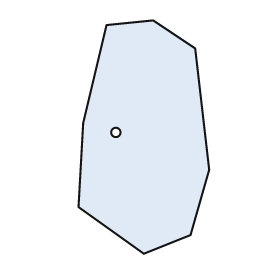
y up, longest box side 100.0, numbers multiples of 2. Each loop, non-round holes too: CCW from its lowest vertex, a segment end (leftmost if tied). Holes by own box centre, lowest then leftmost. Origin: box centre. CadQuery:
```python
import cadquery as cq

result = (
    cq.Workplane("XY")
    .moveTo(0.0, -50.0)
    .lineTo(20.0, -42.0)
    .lineTo(28.0, -14.0)
    .lineTo(22.0, 38.0)
    .lineTo(4.0, 50.0)
    .lineTo(-16.0, 48.0)
    .lineTo(-26.0, 6.0)
    .lineTo(-28.0, -30.0)
    .close()
    .moveTo(-12.0, 2.0)
    .circle(2.0)
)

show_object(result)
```